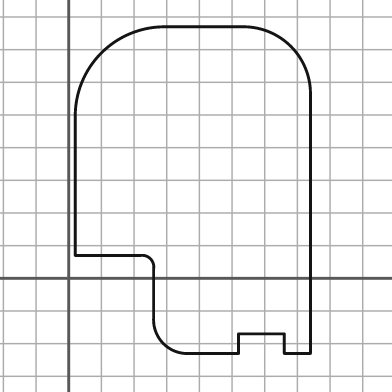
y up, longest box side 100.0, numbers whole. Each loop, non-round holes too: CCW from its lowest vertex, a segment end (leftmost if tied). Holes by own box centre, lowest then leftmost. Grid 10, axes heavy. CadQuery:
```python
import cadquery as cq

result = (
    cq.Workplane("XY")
    .moveTo(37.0, -23.0)
    .lineTo(52.0, -23.0)
    .lineTo(52.0, -17.0)
    .lineTo(66.0, -17.0)
    .lineTo(66.0, -23.0)
    .lineTo(74.0, -23.0)
    .lineTo(74.0, 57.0)
    .threePointArc((68.0, 71.0), (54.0, 77.0))
    .lineTo(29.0, 77.0)
    .threePointArc((10.0, 69.0), (2.0, 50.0))
    .lineTo(2.0, 7.0)
    .lineTo(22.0, 7.0)
    .threePointArc((25.0, 6.0), (26.0, 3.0))
    .lineTo(26.0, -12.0)
    .threePointArc((29.0, -20.0), (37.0, -23.0))
    .close()
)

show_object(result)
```